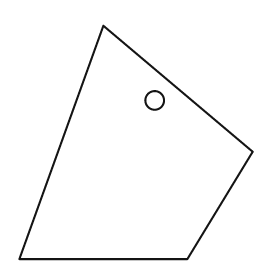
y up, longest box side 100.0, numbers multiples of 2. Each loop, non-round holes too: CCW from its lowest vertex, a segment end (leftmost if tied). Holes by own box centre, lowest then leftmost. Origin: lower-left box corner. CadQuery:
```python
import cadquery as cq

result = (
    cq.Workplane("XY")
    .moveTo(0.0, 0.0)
    .lineTo(72.0, 0.0)
    .lineTo(100.0, 46.0)
    .lineTo(36.0, 100.0)
    .close()
    .moveTo(58.0, 68.0)
    .circle(4.0)
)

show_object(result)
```